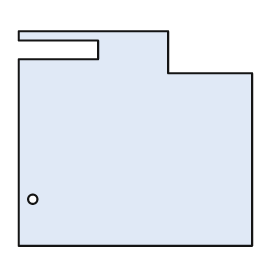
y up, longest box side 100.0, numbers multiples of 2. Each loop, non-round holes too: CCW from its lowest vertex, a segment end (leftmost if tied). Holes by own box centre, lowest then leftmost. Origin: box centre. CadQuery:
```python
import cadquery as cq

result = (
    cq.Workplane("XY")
    .moveTo(-50.0, -46.0)
    .lineTo(50.0, -46.0)
    .lineTo(50.0, 28.0)
    .lineTo(14.0, 28.0)
    .lineTo(14.0, 46.0)
    .lineTo(-50.0, 46.0)
    .lineTo(-50.0, 42.0)
    .lineTo(-16.0, 42.0)
    .lineTo(-16.0, 34.0)
    .lineTo(-50.0, 34.0)
    .close()
    .moveTo(-44.0, -26.0)
    .circle(2.0)
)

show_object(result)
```